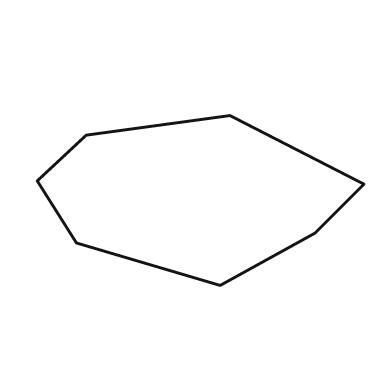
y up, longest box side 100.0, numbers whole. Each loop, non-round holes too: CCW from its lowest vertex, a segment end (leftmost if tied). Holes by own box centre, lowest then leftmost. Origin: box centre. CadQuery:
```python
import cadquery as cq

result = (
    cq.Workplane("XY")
    .moveTo(6.0, -26.0)
    .lineTo(35.0, -10.0)
    .lineTo(50.0, 5.0)
    .lineTo(9.0, 26.0)
    .lineTo(-35.0, 20.0)
    .lineTo(-50.0, 6.0)
    .lineTo(-38.0, -13.0)
    .close()
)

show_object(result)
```